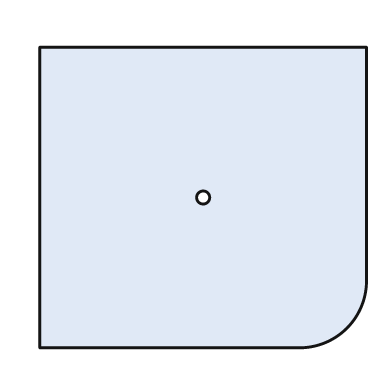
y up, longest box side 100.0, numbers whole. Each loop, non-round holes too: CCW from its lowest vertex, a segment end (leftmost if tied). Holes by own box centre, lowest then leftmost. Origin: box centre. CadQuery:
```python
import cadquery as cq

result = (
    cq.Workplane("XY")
    .moveTo(-50.0, -46.0)
    .lineTo(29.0, -46.0)
    .threePointArc((44.0, -40.0), (50.0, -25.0))
    .lineTo(50.0, 46.0)
    .lineTo(-50.0, 46.0)
    .close()
    .moveTo(0.0, 0.0)
    .circle(2.0)
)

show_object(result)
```